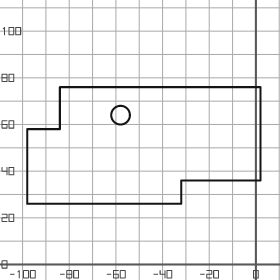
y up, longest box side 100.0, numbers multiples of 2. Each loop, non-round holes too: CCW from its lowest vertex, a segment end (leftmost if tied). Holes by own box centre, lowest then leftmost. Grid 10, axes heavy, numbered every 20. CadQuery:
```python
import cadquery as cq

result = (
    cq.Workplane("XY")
    .moveTo(-98.0, 26.0)
    .lineTo(-32.0, 26.0)
    .lineTo(-32.0, 36.0)
    .lineTo(2.0, 36.0)
    .lineTo(2.0, 76.0)
    .lineTo(-84.0, 76.0)
    .lineTo(-84.0, 58.0)
    .lineTo(-98.0, 58.0)
    .close()
    .moveTo(-58.0, 64.0)
    .circle(4.0)
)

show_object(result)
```